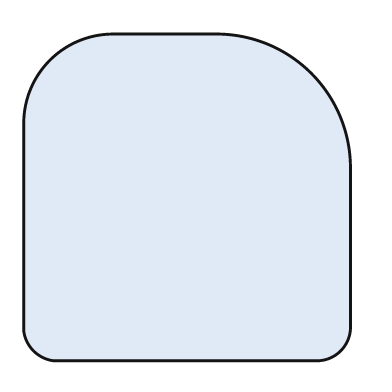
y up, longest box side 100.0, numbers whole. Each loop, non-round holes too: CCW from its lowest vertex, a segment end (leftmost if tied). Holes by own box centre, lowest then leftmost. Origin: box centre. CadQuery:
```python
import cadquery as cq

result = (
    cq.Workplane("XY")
    .moveTo(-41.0, -50.0)
    .lineTo(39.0, -50.0)
    .threePointArc((47.0, -47.0), (50.0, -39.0))
    .lineTo(50.0, 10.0)
    .threePointArc((38.0, 38.0), (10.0, 50.0))
    .lineTo(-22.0, 50.0)
    .threePointArc((-42.0, 42.0), (-50.0, 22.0))
    .lineTo(-50.0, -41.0)
    .threePointArc((-47.0, -47.0), (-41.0, -50.0))
    .close()
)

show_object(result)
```